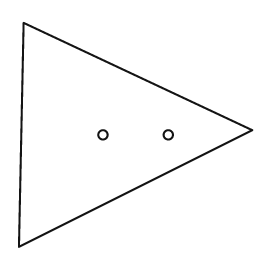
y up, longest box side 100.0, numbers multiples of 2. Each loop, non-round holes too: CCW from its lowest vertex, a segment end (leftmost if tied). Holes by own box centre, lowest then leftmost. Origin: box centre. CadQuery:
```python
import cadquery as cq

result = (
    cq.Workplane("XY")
    .moveTo(-50.0, -48.0)
    .lineTo(50.0, 2.0)
    .lineTo(-48.0, 48.0)
    .close()
    .moveTo(-14.0, 0.0)
    .circle(2.0)
    .moveTo(14.0, 0.0)
    .circle(2.0)
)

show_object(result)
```